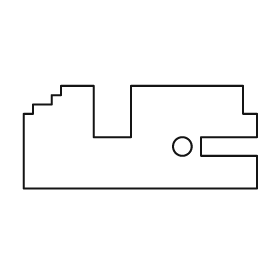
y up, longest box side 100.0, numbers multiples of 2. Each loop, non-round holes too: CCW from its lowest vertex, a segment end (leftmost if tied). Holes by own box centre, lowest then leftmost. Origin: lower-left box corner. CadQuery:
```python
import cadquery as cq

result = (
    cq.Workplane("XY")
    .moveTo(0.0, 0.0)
    .lineTo(100.0, 0.0)
    .lineTo(100.0, 14.0)
    .lineTo(76.0, 14.0)
    .lineTo(76.0, 22.0)
    .lineTo(100.0, 22.0)
    .lineTo(100.0, 32.0)
    .lineTo(94.0, 32.0)
    .lineTo(94.0, 44.0)
    .lineTo(46.0, 44.0)
    .lineTo(46.0, 22.0)
    .lineTo(30.0, 22.0)
    .lineTo(30.0, 44.0)
    .lineTo(16.0, 44.0)
    .lineTo(16.0, 40.0)
    .lineTo(12.0, 40.0)
    .lineTo(12.0, 36.0)
    .lineTo(4.0, 36.0)
    .lineTo(4.0, 32.0)
    .lineTo(0.0, 32.0)
    .close()
    .moveTo(68.0, 18.0)
    .circle(4.0)
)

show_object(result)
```